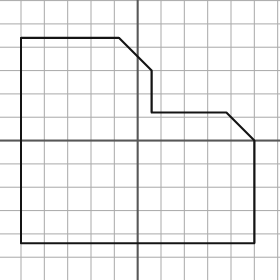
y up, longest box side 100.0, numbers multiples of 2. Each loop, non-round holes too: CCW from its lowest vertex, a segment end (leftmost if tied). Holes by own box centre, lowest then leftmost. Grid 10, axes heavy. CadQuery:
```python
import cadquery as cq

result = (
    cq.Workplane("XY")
    .moveTo(-50.0, -44.0)
    .lineTo(50.0, -44.0)
    .lineTo(50.0, 0.0)
    .lineTo(38.0, 12.0)
    .lineTo(6.0, 12.0)
    .lineTo(6.0, 30.0)
    .lineTo(-8.0, 44.0)
    .lineTo(-50.0, 44.0)
    .close()
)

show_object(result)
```